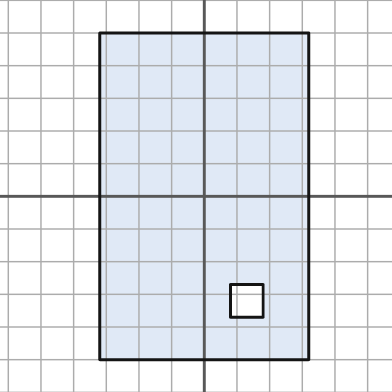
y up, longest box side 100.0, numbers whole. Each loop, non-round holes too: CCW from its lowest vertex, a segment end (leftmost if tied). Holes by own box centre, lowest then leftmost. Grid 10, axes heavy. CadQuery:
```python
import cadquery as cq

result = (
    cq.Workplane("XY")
    .moveTo(-32.0, -50.0)
    .lineTo(32.0, -50.0)
    .lineTo(32.0, 50.0)
    .lineTo(-32.0, 50.0)
    .close()
    .moveTo(8.0, -37.0)
    .lineTo(18.0, -37.0)
    .lineTo(18.0, -27.0)
    .lineTo(8.0, -27.0)
    .close()
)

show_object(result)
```